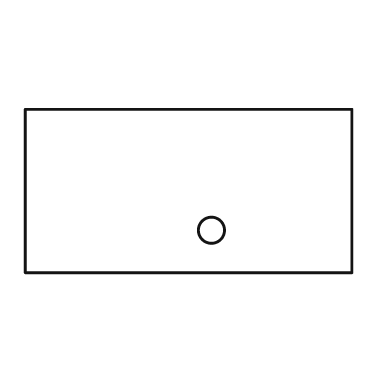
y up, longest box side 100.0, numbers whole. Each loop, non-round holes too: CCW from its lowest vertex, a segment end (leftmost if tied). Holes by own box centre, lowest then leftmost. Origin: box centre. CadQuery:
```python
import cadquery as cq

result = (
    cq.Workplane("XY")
    .moveTo(-50.0, -25.0)
    .lineTo(50.0, -25.0)
    .lineTo(50.0, 25.0)
    .lineTo(-50.0, 25.0)
    .close()
    .moveTo(7.0, -12.0)
    .circle(4.0)
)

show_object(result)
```